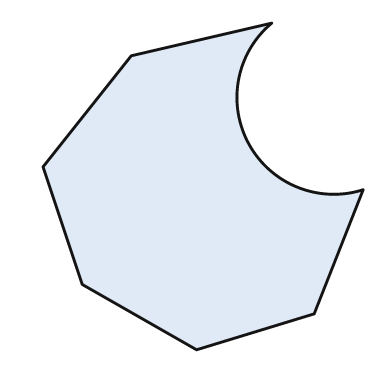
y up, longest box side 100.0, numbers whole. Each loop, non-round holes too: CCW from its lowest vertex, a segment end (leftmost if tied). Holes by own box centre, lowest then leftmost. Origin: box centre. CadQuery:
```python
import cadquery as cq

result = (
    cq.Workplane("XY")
    .moveTo(-2.0, -50.0)
    .lineTo(34.0, -39.0)
    .lineTo(49.0, -1.0)
    .threePointArc((14.0, 13.0), (21.0, 50.0))
    .lineTo(-22.0, 40.0)
    .lineTo(-49.0, 6.0)
    .lineTo(-37.0, -30.0)
    .close()
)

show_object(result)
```